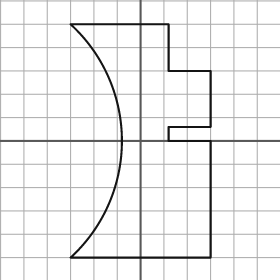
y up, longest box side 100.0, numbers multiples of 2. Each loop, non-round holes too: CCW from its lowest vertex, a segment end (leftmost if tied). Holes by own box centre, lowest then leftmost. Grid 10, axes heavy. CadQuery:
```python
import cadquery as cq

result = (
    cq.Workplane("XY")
    .moveTo(-30.0, -50.0)
    .lineTo(30.0, -50.0)
    .lineTo(30.0, 0.0)
    .lineTo(12.0, 0.0)
    .lineTo(12.0, 6.0)
    .lineTo(30.0, 6.0)
    .lineTo(30.0, 30.0)
    .lineTo(12.0, 30.0)
    .lineTo(12.0, 50.0)
    .lineTo(-30.0, 50.0)
    .threePointArc((-8.0, 0.0), (-30.0, -50.0))
    .close()
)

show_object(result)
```